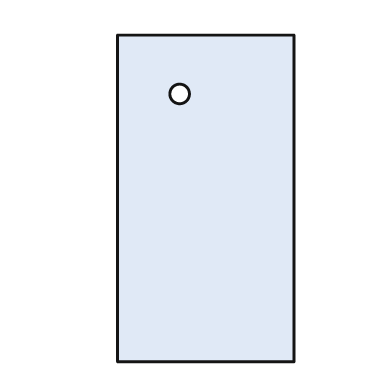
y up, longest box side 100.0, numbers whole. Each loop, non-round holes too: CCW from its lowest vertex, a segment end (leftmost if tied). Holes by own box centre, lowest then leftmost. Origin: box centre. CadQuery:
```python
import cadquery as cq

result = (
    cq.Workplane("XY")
    .moveTo(-27.0, -50.0)
    .lineTo(27.0, -50.0)
    .lineTo(27.0, 50.0)
    .lineTo(-27.0, 50.0)
    .close()
    .moveTo(-8.0, 32.0)
    .circle(3.0)
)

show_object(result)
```